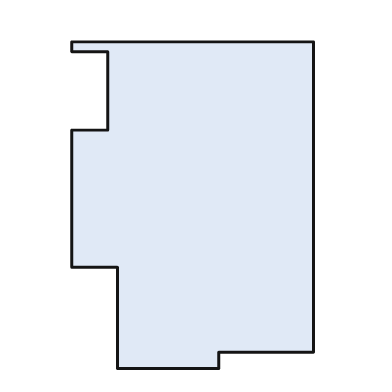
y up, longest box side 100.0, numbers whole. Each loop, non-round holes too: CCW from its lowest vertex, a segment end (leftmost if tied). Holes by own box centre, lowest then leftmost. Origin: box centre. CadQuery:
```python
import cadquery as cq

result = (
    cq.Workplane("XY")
    .moveTo(-23.0, -50.0)
    .lineTo(8.0, -50.0)
    .lineTo(8.0, -45.0)
    .lineTo(37.0, -45.0)
    .lineTo(37.0, 50.0)
    .lineTo(-37.0, 50.0)
    .lineTo(-37.0, 47.0)
    .lineTo(-26.0, 47.0)
    .lineTo(-26.0, 23.0)
    .lineTo(-37.0, 23.0)
    .lineTo(-37.0, -19.0)
    .lineTo(-23.0, -19.0)
    .close()
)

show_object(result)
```